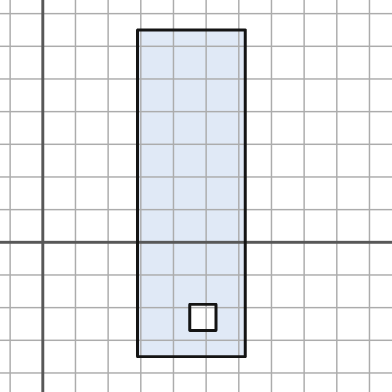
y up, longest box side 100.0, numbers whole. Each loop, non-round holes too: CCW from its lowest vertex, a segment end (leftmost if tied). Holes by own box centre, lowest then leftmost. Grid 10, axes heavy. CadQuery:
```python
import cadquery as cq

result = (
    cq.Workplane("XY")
    .moveTo(29.0, -35.0)
    .lineTo(62.0, -35.0)
    .lineTo(62.0, 65.0)
    .lineTo(29.0, 65.0)
    .close()
    .moveTo(45.0, -27.0)
    .lineTo(53.0, -27.0)
    .lineTo(53.0, -19.0)
    .lineTo(45.0, -19.0)
    .close()
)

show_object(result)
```